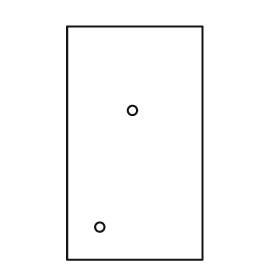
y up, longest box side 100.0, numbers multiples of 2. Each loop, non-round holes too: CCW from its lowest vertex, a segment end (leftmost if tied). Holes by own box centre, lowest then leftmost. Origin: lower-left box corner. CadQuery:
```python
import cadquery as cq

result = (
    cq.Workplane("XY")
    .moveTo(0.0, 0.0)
    .lineTo(58.0, 0.0)
    .lineTo(58.0, 100.0)
    .lineTo(0.0, 100.0)
    .close()
    .moveTo(14.0, 14.0)
    .circle(2.0)
    .moveTo(28.0, 64.0)
    .circle(2.0)
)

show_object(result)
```